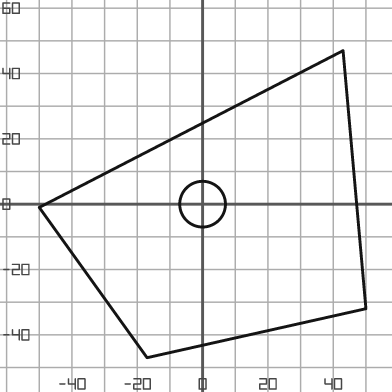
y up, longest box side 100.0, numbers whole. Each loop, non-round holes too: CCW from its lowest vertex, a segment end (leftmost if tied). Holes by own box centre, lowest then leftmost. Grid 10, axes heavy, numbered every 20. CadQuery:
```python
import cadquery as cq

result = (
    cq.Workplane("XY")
    .moveTo(-17.0, -47.0)
    .lineTo(50.0, -32.0)
    .lineTo(43.0, 47.0)
    .lineTo(-50.0, -1.0)
    .close()
    .moveTo(0.0, 0.0)
    .circle(7.0)
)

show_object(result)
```